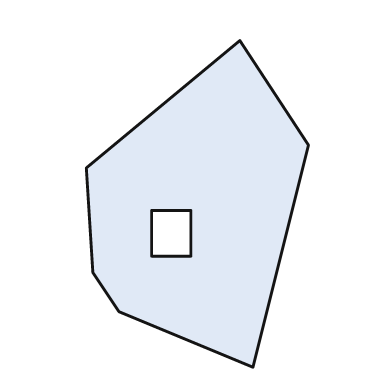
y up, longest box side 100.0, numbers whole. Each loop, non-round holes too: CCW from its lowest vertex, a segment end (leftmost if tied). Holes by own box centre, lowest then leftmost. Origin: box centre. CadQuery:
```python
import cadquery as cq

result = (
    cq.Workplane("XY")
    .moveTo(17.0, -50.0)
    .lineTo(34.0, 18.0)
    .lineTo(13.0, 50.0)
    .lineTo(-34.0, 11.0)
    .lineTo(-32.0, -21.0)
    .lineTo(-24.0, -33.0)
    .close()
    .moveTo(-14.0, -16.0)
    .lineTo(-2.0, -16.0)
    .lineTo(-2.0, -2.0)
    .lineTo(-14.0, -2.0)
    .close()
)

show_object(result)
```